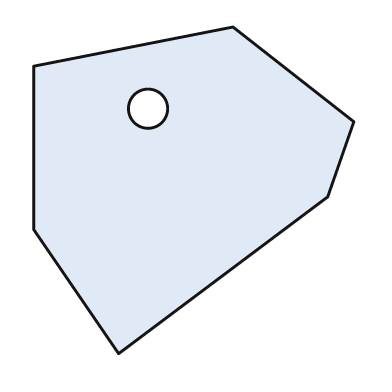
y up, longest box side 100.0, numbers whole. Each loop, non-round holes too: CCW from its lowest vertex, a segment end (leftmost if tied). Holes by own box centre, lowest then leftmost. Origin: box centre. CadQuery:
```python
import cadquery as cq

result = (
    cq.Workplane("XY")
    .moveTo(-23.0, -50.0)
    .lineTo(41.0, -2.0)
    .lineTo(49.0, 21.0)
    .lineTo(12.0, 50.0)
    .lineTo(-49.0, 38.0)
    .lineTo(-49.0, -12.0)
    .close()
    .moveTo(-14.0, 25.0)
    .circle(6.0)
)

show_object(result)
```